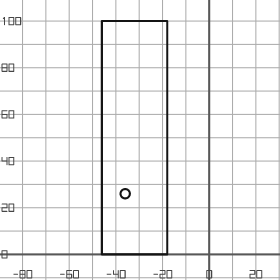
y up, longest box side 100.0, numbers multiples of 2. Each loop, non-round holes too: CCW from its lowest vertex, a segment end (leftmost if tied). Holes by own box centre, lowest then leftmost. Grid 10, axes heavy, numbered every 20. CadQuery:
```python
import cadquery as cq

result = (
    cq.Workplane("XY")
    .moveTo(-46.0, 0.0)
    .lineTo(-18.0, 0.0)
    .lineTo(-18.0, 100.0)
    .lineTo(-46.0, 100.0)
    .close()
    .moveTo(-36.0, 26.0)
    .circle(2.0)
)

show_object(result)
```